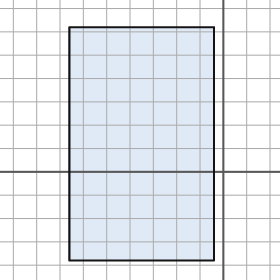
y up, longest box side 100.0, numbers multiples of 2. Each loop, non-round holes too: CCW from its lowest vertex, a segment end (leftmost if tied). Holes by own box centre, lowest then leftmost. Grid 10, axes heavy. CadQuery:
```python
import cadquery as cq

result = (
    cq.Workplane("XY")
    .moveTo(-66.0, -38.0)
    .lineTo(-4.0, -38.0)
    .lineTo(-4.0, 62.0)
    .lineTo(-66.0, 62.0)
    .close()
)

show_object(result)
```